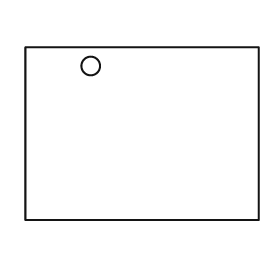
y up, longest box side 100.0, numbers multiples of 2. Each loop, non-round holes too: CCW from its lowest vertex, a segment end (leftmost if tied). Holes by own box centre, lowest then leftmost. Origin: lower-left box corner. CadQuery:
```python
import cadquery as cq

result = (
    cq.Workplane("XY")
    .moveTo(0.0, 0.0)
    .lineTo(100.0, 0.0)
    .lineTo(100.0, 74.0)
    .lineTo(0.0, 74.0)
    .close()
    .moveTo(28.0, 66.0)
    .circle(4.0)
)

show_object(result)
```